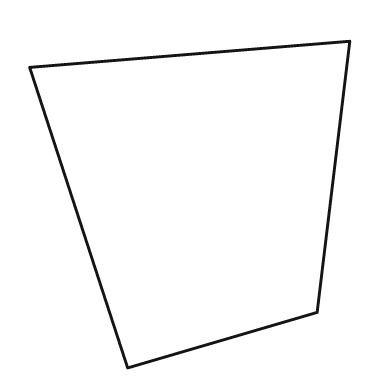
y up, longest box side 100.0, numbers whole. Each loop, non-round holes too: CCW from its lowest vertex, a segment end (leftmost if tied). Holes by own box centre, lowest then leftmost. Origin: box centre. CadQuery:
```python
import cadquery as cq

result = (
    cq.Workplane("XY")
    .moveTo(-19.0, -50.0)
    .lineTo(39.0, -33.0)
    .lineTo(49.0, 50.0)
    .lineTo(-49.0, 42.0)
    .close()
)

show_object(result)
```